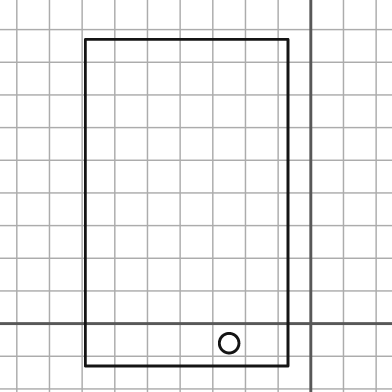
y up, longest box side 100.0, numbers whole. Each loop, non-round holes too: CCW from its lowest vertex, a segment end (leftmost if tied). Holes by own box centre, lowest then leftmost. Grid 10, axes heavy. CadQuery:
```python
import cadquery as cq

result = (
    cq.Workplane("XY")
    .moveTo(-69.0, -13.0)
    .lineTo(-7.0, -13.0)
    .lineTo(-7.0, 87.0)
    .lineTo(-69.0, 87.0)
    .close()
    .moveTo(-25.0, -6.0)
    .circle(3.0)
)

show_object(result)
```